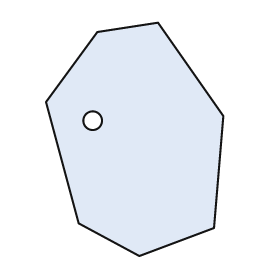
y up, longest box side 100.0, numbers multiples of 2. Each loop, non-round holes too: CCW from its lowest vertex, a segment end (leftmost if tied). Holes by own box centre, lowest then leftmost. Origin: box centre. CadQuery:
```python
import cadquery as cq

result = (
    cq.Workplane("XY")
    .moveTo(2.0, -50.0)
    .lineTo(34.0, -38.0)
    .lineTo(38.0, 10.0)
    .lineTo(10.0, 50.0)
    .lineTo(-16.0, 46.0)
    .lineTo(-38.0, 16.0)
    .lineTo(-24.0, -36.0)
    .close()
    .moveTo(-18.0, 8.0)
    .circle(4.0)
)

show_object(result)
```